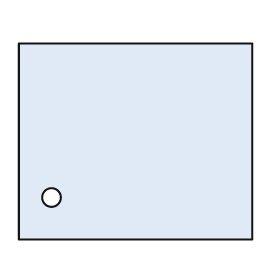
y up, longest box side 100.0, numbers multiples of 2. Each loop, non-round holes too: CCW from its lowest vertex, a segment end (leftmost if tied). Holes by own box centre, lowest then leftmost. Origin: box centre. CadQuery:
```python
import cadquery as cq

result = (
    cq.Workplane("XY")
    .moveTo(-50.0, -42.0)
    .lineTo(50.0, -42.0)
    .lineTo(50.0, 42.0)
    .lineTo(-50.0, 42.0)
    .close()
    .moveTo(-36.0, -24.0)
    .circle(4.0)
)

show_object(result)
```